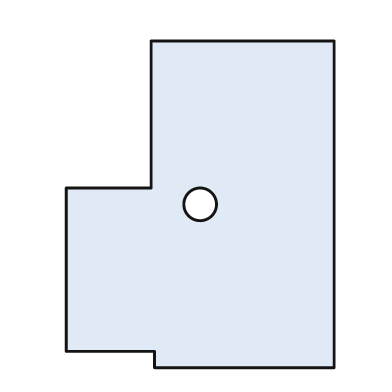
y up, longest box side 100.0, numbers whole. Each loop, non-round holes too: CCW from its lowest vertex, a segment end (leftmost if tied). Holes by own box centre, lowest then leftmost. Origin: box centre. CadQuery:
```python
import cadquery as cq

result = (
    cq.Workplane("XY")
    .moveTo(-14.0, -50.0)
    .lineTo(41.0, -50.0)
    .lineTo(41.0, 50.0)
    .lineTo(-15.0, 50.0)
    .lineTo(-15.0, 5.0)
    .lineTo(-41.0, 5.0)
    .lineTo(-41.0, -45.0)
    .lineTo(-14.0, -45.0)
    .close()
    .moveTo(0.0, 0.0)
    .circle(5.0)
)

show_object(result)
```